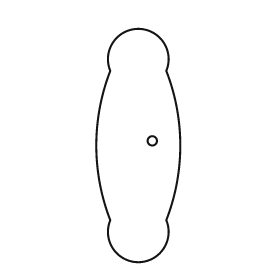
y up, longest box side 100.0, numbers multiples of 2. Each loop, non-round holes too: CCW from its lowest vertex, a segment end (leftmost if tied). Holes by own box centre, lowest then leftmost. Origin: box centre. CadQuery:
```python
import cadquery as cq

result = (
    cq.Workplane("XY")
    .moveTo(-12.0, -32.0)
    .threePointArc((0.0, -50.0), (12.0, -32.0))
    .threePointArc((18.0, 0.0), (12.0, 32.0))
    .threePointArc((0.0, 50.0), (-12.0, 32.0))
    .threePointArc((-18.0, 0.0), (-12.0, -32.0))
    .close()
    .moveTo(6.0, 2.0)
    .circle(2.0)
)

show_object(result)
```